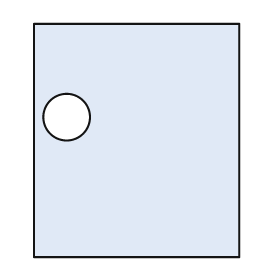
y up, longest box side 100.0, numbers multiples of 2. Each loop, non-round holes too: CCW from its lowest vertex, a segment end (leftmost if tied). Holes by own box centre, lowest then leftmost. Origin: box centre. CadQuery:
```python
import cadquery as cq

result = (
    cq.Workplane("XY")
    .moveTo(-44.0, -50.0)
    .lineTo(44.0, -50.0)
    .lineTo(44.0, 50.0)
    .lineTo(-44.0, 50.0)
    .close()
    .moveTo(-30.0, 10.0)
    .circle(10.0)
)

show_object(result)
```